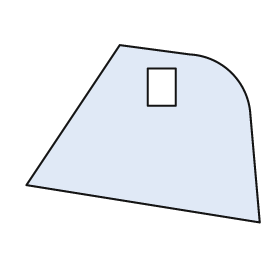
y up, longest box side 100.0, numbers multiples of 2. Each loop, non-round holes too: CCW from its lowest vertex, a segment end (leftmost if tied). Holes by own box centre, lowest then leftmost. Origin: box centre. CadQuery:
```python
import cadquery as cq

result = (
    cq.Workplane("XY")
    .moveTo(50.0, -38.0)
    .lineTo(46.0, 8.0)
    .threePointArc((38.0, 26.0), (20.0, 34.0))
    .lineTo(-10.0, 38.0)
    .lineTo(-50.0, -22.0)
    .close()
    .moveTo(2.0, 12.0)
    .lineTo(14.0, 12.0)
    .lineTo(14.0, 28.0)
    .lineTo(2.0, 28.0)
    .close()
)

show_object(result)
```